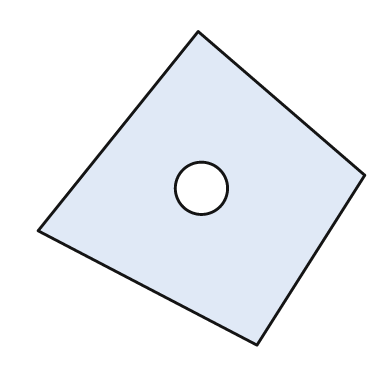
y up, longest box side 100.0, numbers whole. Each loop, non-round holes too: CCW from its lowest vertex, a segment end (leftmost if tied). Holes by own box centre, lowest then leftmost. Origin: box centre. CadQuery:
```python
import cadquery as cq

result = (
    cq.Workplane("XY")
    .moveTo(17.0, -48.0)
    .lineTo(50.0, 4.0)
    .lineTo(-1.0, 48.0)
    .lineTo(-50.0, -13.0)
    .close()
    .moveTo(0.0, 0.0)
    .circle(8.0)
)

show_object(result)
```